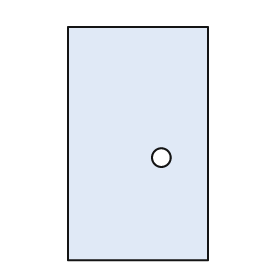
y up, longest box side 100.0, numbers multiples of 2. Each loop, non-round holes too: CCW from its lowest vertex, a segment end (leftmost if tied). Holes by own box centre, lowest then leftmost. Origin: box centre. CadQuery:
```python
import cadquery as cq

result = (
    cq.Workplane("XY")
    .moveTo(-30.0, -50.0)
    .lineTo(30.0, -50.0)
    .lineTo(30.0, 50.0)
    .lineTo(-30.0, 50.0)
    .close()
    .moveTo(10.0, -6.0)
    .circle(4.0)
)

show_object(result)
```